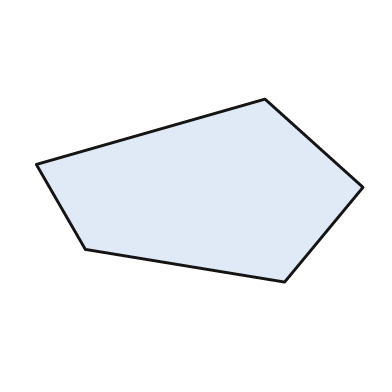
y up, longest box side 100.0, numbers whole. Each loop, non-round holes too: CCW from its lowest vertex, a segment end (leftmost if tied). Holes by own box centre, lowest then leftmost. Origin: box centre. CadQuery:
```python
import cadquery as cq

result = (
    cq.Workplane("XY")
    .moveTo(26.0, -28.0)
    .lineTo(50.0, 1.0)
    .lineTo(20.0, 28.0)
    .lineTo(-50.0, 8.0)
    .lineTo(-35.0, -18.0)
    .close()
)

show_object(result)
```